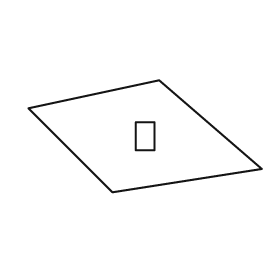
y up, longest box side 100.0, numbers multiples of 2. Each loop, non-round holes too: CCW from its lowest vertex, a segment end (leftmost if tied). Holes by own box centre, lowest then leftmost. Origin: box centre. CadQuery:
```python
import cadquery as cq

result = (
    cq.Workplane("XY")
    .moveTo(-14.0, -24.0)
    .lineTo(50.0, -14.0)
    .lineTo(6.0, 24.0)
    .lineTo(-50.0, 12.0)
    .close()
    .moveTo(-4.0, -6.0)
    .lineTo(4.0, -6.0)
    .lineTo(4.0, 6.0)
    .lineTo(-4.0, 6.0)
    .close()
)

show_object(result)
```